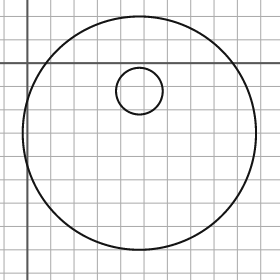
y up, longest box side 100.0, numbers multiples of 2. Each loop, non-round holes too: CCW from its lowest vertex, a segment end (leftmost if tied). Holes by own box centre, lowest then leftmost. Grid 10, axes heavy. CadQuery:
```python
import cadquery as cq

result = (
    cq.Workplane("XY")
    .moveTo(48.0, -30.0)
    .circle(50.0)
    .moveTo(48.0, -12.0)
    .circle(10.0)
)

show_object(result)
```